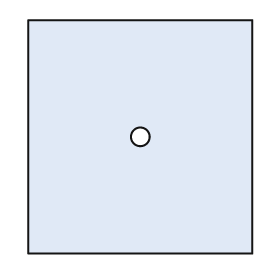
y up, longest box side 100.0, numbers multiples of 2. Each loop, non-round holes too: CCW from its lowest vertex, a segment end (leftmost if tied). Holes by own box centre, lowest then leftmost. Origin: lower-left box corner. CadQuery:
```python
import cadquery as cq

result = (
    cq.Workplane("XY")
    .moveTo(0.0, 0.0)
    .lineTo(96.0, 0.0)
    .lineTo(96.0, 100.0)
    .lineTo(0.0, 100.0)
    .close()
    .moveTo(48.0, 50.0)
    .circle(4.0)
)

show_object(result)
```